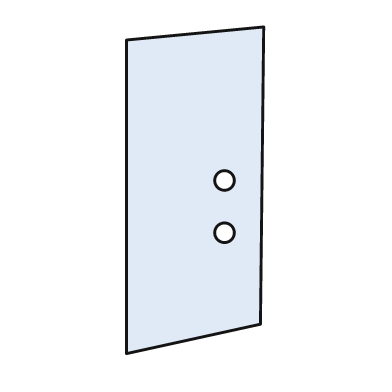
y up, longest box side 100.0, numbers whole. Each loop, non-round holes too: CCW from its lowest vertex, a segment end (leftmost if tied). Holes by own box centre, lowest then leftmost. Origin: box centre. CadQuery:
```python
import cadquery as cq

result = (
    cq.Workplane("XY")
    .moveTo(-21.0, -50.0)
    .lineTo(20.0, -41.0)
    .lineTo(21.0, 50.0)
    .lineTo(-21.0, 46.0)
    .close()
    .moveTo(9.0, -13.0)
    .circle(3.0)
    .moveTo(9.0, 3.0)
    .circle(3.0)
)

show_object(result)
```